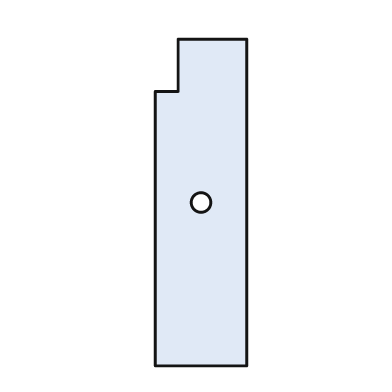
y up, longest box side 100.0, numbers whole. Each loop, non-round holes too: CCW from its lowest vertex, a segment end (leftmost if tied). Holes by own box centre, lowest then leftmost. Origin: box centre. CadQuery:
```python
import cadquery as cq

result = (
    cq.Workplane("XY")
    .moveTo(-14.0, -50.0)
    .lineTo(14.0, -50.0)
    .lineTo(14.0, 50.0)
    .lineTo(-7.0, 50.0)
    .lineTo(-7.0, 34.0)
    .lineTo(-14.0, 34.0)
    .close()
    .moveTo(0.0, 0.0)
    .circle(3.0)
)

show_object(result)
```